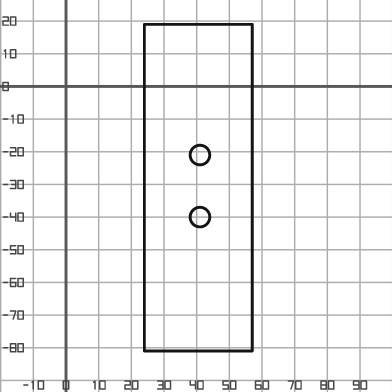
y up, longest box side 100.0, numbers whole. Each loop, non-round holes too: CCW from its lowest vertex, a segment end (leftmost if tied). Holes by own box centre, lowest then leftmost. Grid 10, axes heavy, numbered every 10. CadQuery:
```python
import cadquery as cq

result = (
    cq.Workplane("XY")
    .moveTo(24.0, -81.0)
    .lineTo(57.0, -81.0)
    .lineTo(57.0, 19.0)
    .lineTo(24.0, 19.0)
    .close()
    .moveTo(41.0, -40.0)
    .circle(3.0)
    .moveTo(41.0, -21.0)
    .circle(3.0)
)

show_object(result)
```